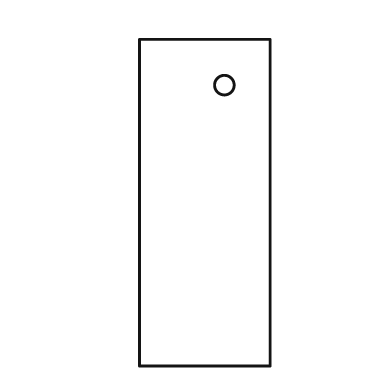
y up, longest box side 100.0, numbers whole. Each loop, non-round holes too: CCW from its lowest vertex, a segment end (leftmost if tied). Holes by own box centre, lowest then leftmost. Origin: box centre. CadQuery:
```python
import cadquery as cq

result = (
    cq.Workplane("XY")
    .moveTo(-20.0, -50.0)
    .lineTo(20.0, -50.0)
    .lineTo(20.0, 50.0)
    .lineTo(-20.0, 50.0)
    .close()
    .moveTo(6.0, 36.0)
    .circle(3.0)
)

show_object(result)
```